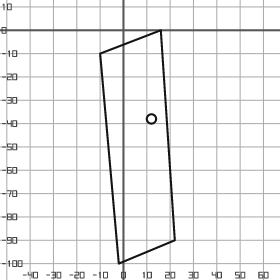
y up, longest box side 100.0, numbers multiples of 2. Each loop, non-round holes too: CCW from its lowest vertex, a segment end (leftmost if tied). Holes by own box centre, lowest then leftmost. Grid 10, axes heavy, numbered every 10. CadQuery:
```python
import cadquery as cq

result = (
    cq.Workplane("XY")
    .moveTo(-2.0, -100.0)
    .lineTo(22.0, -90.0)
    .lineTo(16.0, 0.0)
    .lineTo(-10.0, -10.0)
    .close()
    .moveTo(12.0, -38.0)
    .circle(2.0)
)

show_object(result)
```